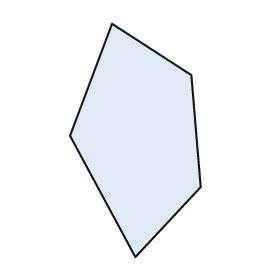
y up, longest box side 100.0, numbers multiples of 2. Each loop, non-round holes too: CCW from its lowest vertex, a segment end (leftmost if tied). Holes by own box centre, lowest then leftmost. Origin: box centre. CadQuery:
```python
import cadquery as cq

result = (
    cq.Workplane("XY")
    .moveTo(0.0, -50.0)
    .lineTo(28.0, -20.0)
    .lineTo(24.0, 28.0)
    .lineTo(-10.0, 50.0)
    .lineTo(-28.0, 2.0)
    .close()
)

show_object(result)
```